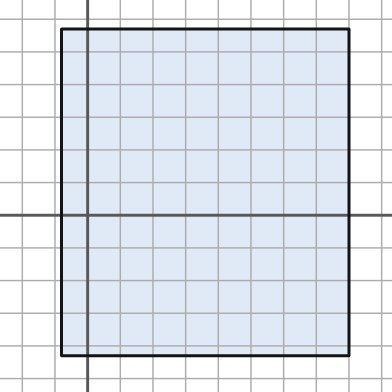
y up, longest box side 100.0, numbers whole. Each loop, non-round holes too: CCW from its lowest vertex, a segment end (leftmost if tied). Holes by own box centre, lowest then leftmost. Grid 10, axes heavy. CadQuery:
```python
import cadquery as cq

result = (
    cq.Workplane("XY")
    .moveTo(-8.0, -43.0)
    .lineTo(80.0, -43.0)
    .lineTo(80.0, 57.0)
    .lineTo(-8.0, 57.0)
    .close()
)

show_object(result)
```